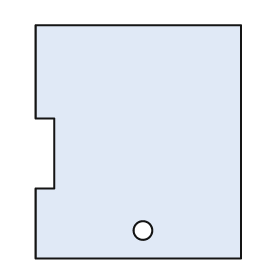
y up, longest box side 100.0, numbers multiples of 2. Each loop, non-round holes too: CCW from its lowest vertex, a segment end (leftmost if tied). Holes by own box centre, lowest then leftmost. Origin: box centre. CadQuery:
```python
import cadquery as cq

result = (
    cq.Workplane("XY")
    .moveTo(-44.0, -50.0)
    .lineTo(44.0, -50.0)
    .lineTo(44.0, 50.0)
    .lineTo(-44.0, 50.0)
    .lineTo(-44.0, 10.0)
    .lineTo(-36.0, 10.0)
    .lineTo(-36.0, -20.0)
    .lineTo(-44.0, -20.0)
    .close()
    .moveTo(2.0, -38.0)
    .circle(4.0)
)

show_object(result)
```